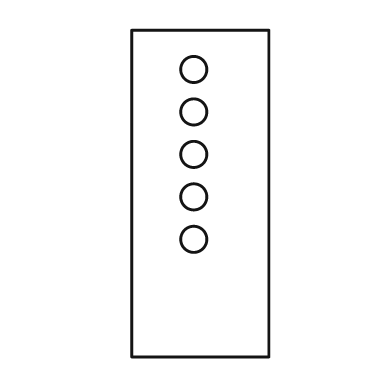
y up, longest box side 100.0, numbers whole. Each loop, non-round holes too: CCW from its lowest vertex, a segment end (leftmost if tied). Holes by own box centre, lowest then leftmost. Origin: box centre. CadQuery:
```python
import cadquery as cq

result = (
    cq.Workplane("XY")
    .moveTo(-21.0, -50.0)
    .lineTo(21.0, -50.0)
    .lineTo(21.0, 50.0)
    .lineTo(-21.0, 50.0)
    .close()
    .moveTo(-2.0, -14.0)
    .circle(4.0)
    .moveTo(-2.0, -1.0)
    .circle(4.0)
    .moveTo(-2.0, 12.0)
    .circle(4.0)
    .moveTo(-2.0, 25.0)
    .circle(4.0)
    .moveTo(-2.0, 38.0)
    .circle(4.0)
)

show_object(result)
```